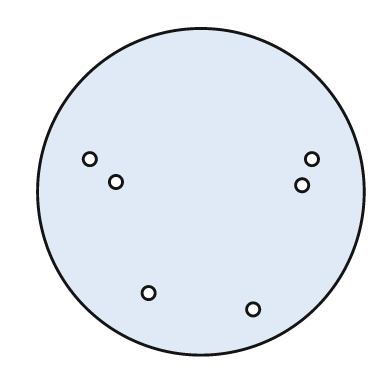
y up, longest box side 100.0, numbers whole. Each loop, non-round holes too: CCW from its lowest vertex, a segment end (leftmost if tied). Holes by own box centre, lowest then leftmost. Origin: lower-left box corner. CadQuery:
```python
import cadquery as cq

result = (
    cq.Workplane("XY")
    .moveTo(50.0, 50.0)
    .circle(50.0)
    .moveTo(66.0, 14.0)
    .circle(2.0)
    .moveTo(34.0, 19.0)
    .circle(2.0)
    .moveTo(81.0, 52.0)
    .circle(2.0)
    .moveTo(24.0, 53.0)
    .circle(2.0)
    .moveTo(16.0, 60.0)
    .circle(2.0)
    .moveTo(84.0, 60.0)
    .circle(2.0)
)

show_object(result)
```